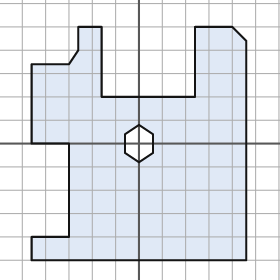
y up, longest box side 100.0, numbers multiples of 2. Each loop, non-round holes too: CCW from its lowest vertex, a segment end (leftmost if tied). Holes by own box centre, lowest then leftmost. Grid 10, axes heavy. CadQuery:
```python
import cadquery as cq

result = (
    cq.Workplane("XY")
    .moveTo(-46.0, -50.0)
    .lineTo(46.0, -50.0)
    .lineTo(46.0, 44.0)
    .lineTo(40.0, 50.0)
    .lineTo(24.0, 50.0)
    .lineTo(24.0, 20.0)
    .lineTo(-16.0, 20.0)
    .lineTo(-16.0, 50.0)
    .lineTo(-26.0, 50.0)
    .lineTo(-26.0, 40.0)
    .lineTo(-30.0, 34.0)
    .lineTo(-46.0, 34.0)
    .lineTo(-46.0, 0.0)
    .lineTo(-30.0, 0.0)
    .lineTo(-30.0, -40.0)
    .lineTo(-46.0, -40.0)
    .close()
    .moveTo(0.0, -8.0)
    .lineTo(6.0, -4.0)
    .lineTo(6.0, 4.0)
    .lineTo(0.0, 8.0)
    .lineTo(-6.0, 4.0)
    .lineTo(-6.0, -4.0)
    .close()
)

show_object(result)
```